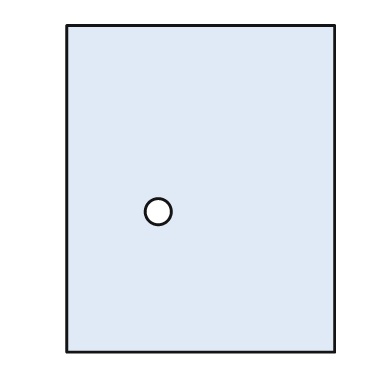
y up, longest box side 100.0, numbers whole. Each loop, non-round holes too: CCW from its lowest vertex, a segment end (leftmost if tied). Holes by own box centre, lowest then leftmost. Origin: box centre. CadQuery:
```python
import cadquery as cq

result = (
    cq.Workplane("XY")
    .moveTo(-41.0, -50.0)
    .lineTo(41.0, -50.0)
    .lineTo(41.0, 50.0)
    .lineTo(-41.0, 50.0)
    .close()
    .moveTo(-13.0, -7.0)
    .circle(4.0)
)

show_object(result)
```